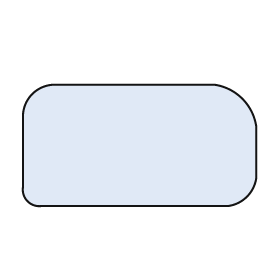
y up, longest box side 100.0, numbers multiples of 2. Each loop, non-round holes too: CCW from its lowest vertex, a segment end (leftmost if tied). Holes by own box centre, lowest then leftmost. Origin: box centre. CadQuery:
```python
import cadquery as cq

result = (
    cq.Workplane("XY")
    .moveTo(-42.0, -26.0)
    .lineTo(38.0, -26.0)
    .threePointArc((46.0, -22.0), (50.0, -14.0))
    .lineTo(50.0, 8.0)
    .threePointArc((44.0, 20.0), (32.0, 26.0))
    .lineTo(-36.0, 26.0)
    .threePointArc((-46.0, 22.0), (-50.0, 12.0))
    .lineTo(-50.0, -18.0)
    .threePointArc((-48.0, -24.0), (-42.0, -26.0))
    .close()
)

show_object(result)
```